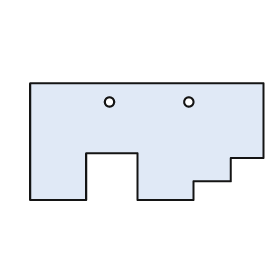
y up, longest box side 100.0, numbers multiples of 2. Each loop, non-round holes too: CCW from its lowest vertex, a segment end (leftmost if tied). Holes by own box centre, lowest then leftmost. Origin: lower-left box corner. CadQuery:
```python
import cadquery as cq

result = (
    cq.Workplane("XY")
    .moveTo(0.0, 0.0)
    .lineTo(24.0, 0.0)
    .lineTo(24.0, 20.0)
    .lineTo(46.0, 20.0)
    .lineTo(46.0, 0.0)
    .lineTo(70.0, 0.0)
    .lineTo(70.0, 8.0)
    .lineTo(86.0, 8.0)
    .lineTo(86.0, 18.0)
    .lineTo(100.0, 18.0)
    .lineTo(100.0, 50.0)
    .lineTo(0.0, 50.0)
    .close()
    .moveTo(34.0, 42.0)
    .circle(2.0)
    .moveTo(68.0, 42.0)
    .circle(2.0)
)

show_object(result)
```